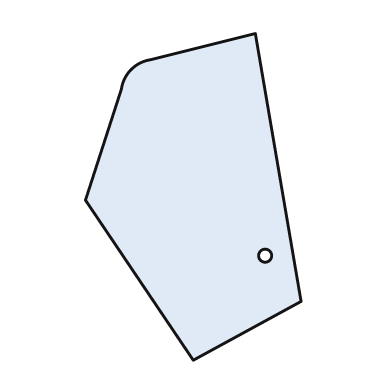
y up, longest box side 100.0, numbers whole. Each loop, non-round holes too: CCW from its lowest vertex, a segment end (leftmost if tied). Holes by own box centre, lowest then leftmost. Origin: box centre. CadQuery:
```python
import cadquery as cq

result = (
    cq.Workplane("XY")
    .moveTo(0.0, -50.0)
    .lineTo(33.0, -32.0)
    .lineTo(19.0, 50.0)
    .lineTo(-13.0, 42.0)
    .threePointArc((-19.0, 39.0), (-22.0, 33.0))
    .lineTo(-33.0, -1.0)
    .close()
    .moveTo(22.0, -18.0)
    .circle(2.0)
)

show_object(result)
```